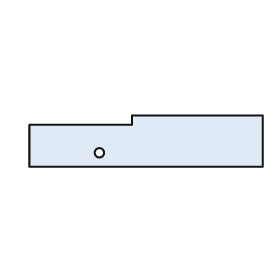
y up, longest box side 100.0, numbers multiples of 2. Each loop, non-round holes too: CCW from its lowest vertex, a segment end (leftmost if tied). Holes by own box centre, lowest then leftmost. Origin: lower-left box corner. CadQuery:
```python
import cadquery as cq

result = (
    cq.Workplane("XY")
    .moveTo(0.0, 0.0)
    .lineTo(100.0, 0.0)
    .lineTo(100.0, 22.0)
    .lineTo(44.0, 22.0)
    .lineTo(44.0, 18.0)
    .lineTo(0.0, 18.0)
    .close()
    .moveTo(30.0, 6.0)
    .circle(2.0)
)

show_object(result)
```